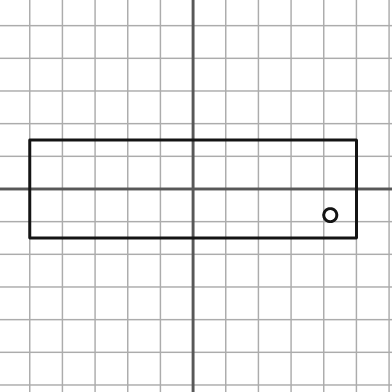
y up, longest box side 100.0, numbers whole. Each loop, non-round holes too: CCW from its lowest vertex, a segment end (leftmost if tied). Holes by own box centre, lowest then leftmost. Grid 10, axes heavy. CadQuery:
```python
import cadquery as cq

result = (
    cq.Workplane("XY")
    .moveTo(-50.0, -15.0)
    .lineTo(50.0, -15.0)
    .lineTo(50.0, 15.0)
    .lineTo(-50.0, 15.0)
    .close()
    .moveTo(42.0, -8.0)
    .circle(2.0)
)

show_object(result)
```